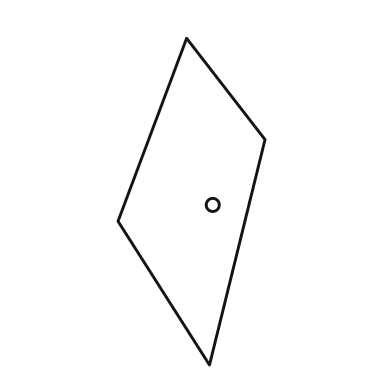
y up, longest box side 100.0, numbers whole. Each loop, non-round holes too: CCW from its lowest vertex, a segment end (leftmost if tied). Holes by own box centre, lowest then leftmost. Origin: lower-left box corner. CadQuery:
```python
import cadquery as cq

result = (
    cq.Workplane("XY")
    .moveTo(28.0, 0.0)
    .lineTo(45.0, 69.0)
    .lineTo(21.0, 100.0)
    .lineTo(0.0, 44.0)
    .close()
    .moveTo(29.0, 49.0)
    .circle(2.0)
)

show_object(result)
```